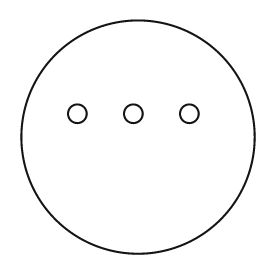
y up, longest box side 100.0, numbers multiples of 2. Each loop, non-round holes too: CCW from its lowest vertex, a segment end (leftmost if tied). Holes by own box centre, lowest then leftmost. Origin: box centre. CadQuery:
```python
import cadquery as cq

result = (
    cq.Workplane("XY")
    .moveTo(0.0, 0.0)
    .circle(50.0)
    .moveTo(-26.0, 10.0)
    .circle(4.0)
    .moveTo(-2.0, 10.0)
    .circle(4.0)
    .moveTo(22.0, 10.0)
    .circle(4.0)
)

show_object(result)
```